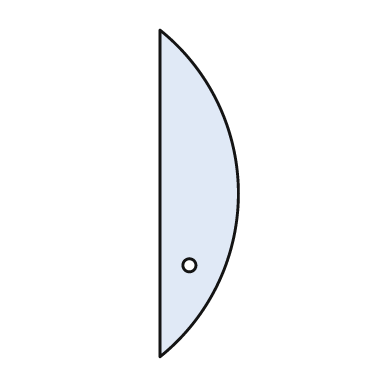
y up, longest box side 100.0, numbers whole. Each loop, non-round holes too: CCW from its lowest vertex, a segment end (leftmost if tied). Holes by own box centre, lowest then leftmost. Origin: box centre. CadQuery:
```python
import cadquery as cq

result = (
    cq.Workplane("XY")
    .moveTo(-12.0, -50.0)
    .threePointArc((12.0, 0.0), (-12.0, 50.0))
    .close()
    .moveTo(-3.0, -22.0)
    .circle(2.0)
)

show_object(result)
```